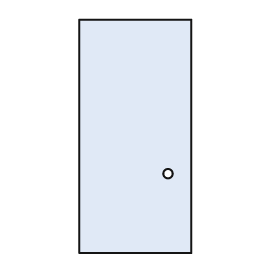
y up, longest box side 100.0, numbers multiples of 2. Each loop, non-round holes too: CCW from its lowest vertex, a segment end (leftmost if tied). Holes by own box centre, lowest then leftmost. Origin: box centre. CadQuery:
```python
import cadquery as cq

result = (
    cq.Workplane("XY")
    .moveTo(-24.0, -50.0)
    .lineTo(24.0, -50.0)
    .lineTo(24.0, 50.0)
    .lineTo(-24.0, 50.0)
    .close()
    .moveTo(14.0, -16.0)
    .circle(2.0)
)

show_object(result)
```